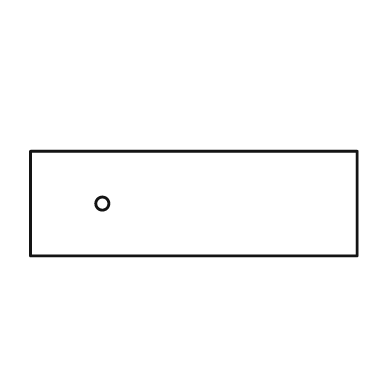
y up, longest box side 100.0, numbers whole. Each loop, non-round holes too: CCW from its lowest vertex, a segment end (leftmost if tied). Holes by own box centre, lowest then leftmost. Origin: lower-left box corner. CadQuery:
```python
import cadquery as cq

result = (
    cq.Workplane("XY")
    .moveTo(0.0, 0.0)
    .lineTo(100.0, 0.0)
    .lineTo(100.0, 32.0)
    .lineTo(0.0, 32.0)
    .close()
    .moveTo(22.0, 16.0)
    .circle(2.0)
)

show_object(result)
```